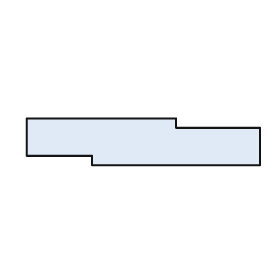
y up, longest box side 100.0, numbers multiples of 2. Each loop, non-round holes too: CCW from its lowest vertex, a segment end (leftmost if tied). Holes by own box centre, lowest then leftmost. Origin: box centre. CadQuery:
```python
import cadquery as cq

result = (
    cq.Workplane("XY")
    .moveTo(-22.0, -10.0)
    .lineTo(50.0, -10.0)
    .lineTo(50.0, 6.0)
    .lineTo(14.0, 6.0)
    .lineTo(14.0, 10.0)
    .lineTo(-50.0, 10.0)
    .lineTo(-50.0, -6.0)
    .lineTo(-22.0, -6.0)
    .close()
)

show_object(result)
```